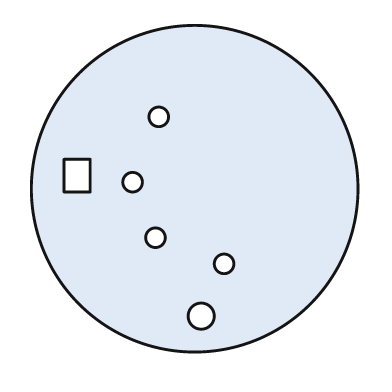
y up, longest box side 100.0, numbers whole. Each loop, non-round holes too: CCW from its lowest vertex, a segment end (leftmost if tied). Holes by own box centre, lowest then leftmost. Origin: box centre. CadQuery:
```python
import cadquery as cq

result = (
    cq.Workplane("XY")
    .moveTo(0.0, 0.0)
    .circle(50.0)
    .moveTo(2.0, -39.0)
    .circle(4.0)
    .moveTo(9.0, -23.0)
    .circle(3.0)
    .moveTo(-12.0, -15.0)
    .circle(3.0)
    .moveTo(-19.0, 2.0)
    .circle(3.0)
    .moveTo(-40.0, -1.0)
    .lineTo(-32.0, -1.0)
    .lineTo(-32.0, 9.0)
    .lineTo(-40.0, 9.0)
    .close()
    .moveTo(-11.0, 22.0)
    .circle(3.0)
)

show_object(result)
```